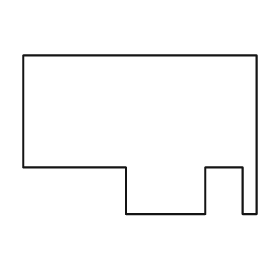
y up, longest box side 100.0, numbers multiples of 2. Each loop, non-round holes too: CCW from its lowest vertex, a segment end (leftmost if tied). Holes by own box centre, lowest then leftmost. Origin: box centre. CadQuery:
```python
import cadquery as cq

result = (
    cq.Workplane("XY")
    .moveTo(-6.0, -34.0)
    .lineTo(28.0, -34.0)
    .lineTo(28.0, -14.0)
    .lineTo(44.0, -14.0)
    .lineTo(44.0, -34.0)
    .lineTo(50.0, -34.0)
    .lineTo(50.0, 34.0)
    .lineTo(-50.0, 34.0)
    .lineTo(-50.0, -14.0)
    .lineTo(-6.0, -14.0)
    .close()
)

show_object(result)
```